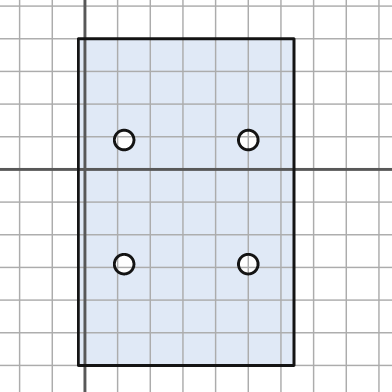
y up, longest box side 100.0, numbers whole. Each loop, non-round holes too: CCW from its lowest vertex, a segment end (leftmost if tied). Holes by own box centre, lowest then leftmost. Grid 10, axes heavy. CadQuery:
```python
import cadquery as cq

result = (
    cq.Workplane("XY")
    .moveTo(-2.0, -60.0)
    .lineTo(64.0, -60.0)
    .lineTo(64.0, 40.0)
    .lineTo(-2.0, 40.0)
    .close()
    .moveTo(12.0, -29.0)
    .circle(3.0)
    .moveTo(50.0, -29.0)
    .circle(3.0)
    .moveTo(12.0, 9.0)
    .circle(3.0)
    .moveTo(50.0, 9.0)
    .circle(3.0)
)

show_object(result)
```